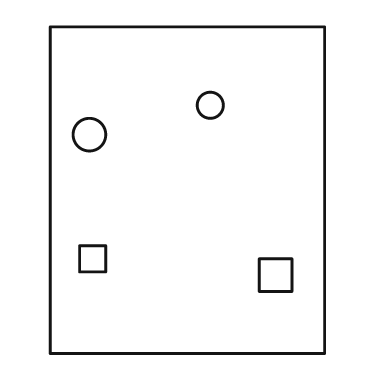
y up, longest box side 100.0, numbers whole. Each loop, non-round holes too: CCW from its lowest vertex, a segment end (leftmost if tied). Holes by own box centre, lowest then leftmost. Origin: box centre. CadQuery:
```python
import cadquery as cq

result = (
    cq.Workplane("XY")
    .moveTo(-42.0, -50.0)
    .lineTo(42.0, -50.0)
    .lineTo(42.0, 50.0)
    .lineTo(-42.0, 50.0)
    .close()
    .moveTo(22.0, -31.0)
    .lineTo(32.0, -31.0)
    .lineTo(32.0, -21.0)
    .lineTo(22.0, -21.0)
    .close()
    .moveTo(-33.0, -25.0)
    .lineTo(-25.0, -25.0)
    .lineTo(-25.0, -17.0)
    .lineTo(-33.0, -17.0)
    .close()
    .moveTo(-30.0, 17.0)
    .circle(5.0)
    .moveTo(7.0, 26.0)
    .circle(4.0)
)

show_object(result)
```